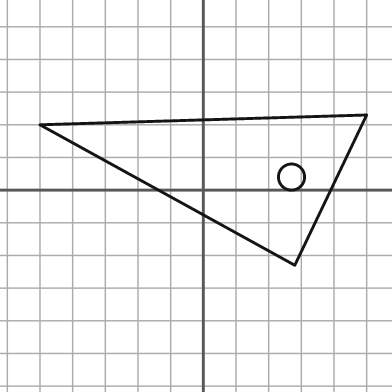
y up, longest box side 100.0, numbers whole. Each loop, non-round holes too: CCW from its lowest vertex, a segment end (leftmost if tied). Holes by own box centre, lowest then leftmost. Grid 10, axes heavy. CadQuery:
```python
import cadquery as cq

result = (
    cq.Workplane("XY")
    .moveTo(28.0, -23.0)
    .lineTo(50.0, 23.0)
    .lineTo(-50.0, 20.0)
    .close()
    .moveTo(27.0, 4.0)
    .circle(4.0)
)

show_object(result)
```